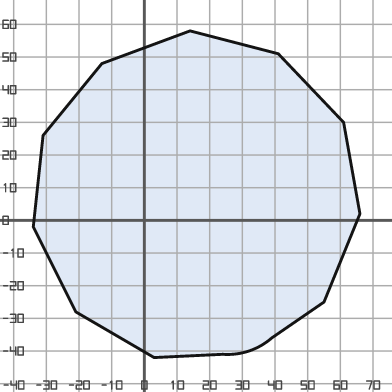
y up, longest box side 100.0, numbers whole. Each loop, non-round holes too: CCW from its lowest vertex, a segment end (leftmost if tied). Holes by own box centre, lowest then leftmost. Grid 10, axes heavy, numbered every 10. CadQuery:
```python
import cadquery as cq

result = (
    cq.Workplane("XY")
    .moveTo(3.0, -42.0)
    .lineTo(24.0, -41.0)
    .threePointArc((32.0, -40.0), (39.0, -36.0))
    .lineTo(55.0, -25.0)
    .lineTo(66.0, 2.0)
    .lineTo(61.0, 30.0)
    .lineTo(41.0, 51.0)
    .lineTo(14.0, 58.0)
    .lineTo(-13.0, 48.0)
    .lineTo(-31.0, 26.0)
    .lineTo(-34.0, -2.0)
    .lineTo(-21.0, -28.0)
    .close()
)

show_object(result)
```